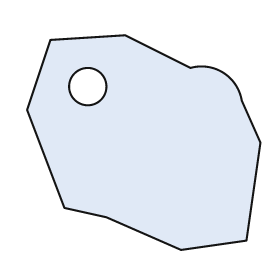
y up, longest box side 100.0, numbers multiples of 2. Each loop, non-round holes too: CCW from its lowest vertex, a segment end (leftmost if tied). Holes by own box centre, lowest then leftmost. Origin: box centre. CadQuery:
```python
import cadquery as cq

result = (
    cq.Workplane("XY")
    .moveTo(16.0, -46.0)
    .lineTo(44.0, -42.0)
    .lineTo(50.0, 0.0)
    .lineTo(42.0, 18.0)
    .threePointArc((34.0, 30.0), (20.0, 32.0))
    .lineTo(-8.0, 46.0)
    .lineTo(-40.0, 44.0)
    .lineTo(-50.0, 14.0)
    .lineTo(-34.0, -28.0)
    .lineTo(-16.0, -32.0)
    .close()
    .moveTo(-24.0, 24.0)
    .circle(8.0)
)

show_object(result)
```